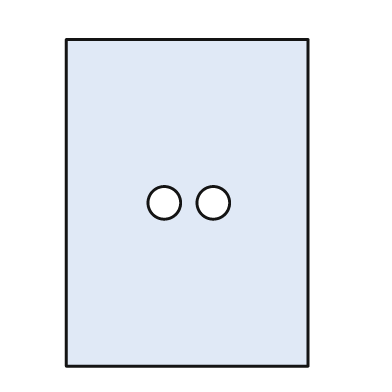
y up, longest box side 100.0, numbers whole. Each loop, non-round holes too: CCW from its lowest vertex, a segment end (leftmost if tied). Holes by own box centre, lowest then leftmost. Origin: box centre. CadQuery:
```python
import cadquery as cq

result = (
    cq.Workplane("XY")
    .moveTo(-37.0, -50.0)
    .lineTo(37.0, -50.0)
    .lineTo(37.0, 50.0)
    .lineTo(-37.0, 50.0)
    .close()
    .moveTo(-7.0, 0.0)
    .circle(5.0)
    .moveTo(8.0, 0.0)
    .circle(5.0)
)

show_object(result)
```